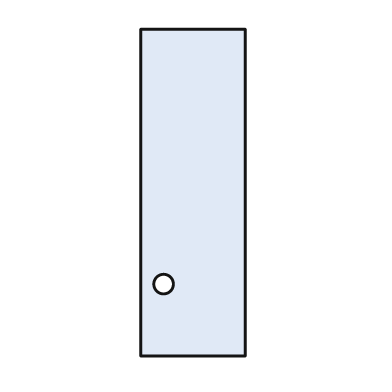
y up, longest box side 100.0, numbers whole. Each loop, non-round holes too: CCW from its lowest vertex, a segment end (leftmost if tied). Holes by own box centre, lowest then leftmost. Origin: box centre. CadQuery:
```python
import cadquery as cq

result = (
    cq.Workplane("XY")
    .moveTo(-16.0, -50.0)
    .lineTo(16.0, -50.0)
    .lineTo(16.0, 50.0)
    .lineTo(-16.0, 50.0)
    .close()
    .moveTo(-9.0, -28.0)
    .circle(3.0)
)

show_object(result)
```